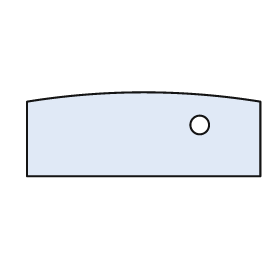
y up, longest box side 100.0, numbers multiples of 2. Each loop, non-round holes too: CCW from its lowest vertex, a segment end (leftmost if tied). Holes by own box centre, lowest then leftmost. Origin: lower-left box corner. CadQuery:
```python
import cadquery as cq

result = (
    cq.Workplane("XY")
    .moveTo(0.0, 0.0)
    .lineTo(100.0, 0.0)
    .lineTo(100.0, 32.0)
    .threePointArc((50.0, 36.0), (0.0, 32.0))
    .close()
    .moveTo(74.0, 22.0)
    .circle(4.0)
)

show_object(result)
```